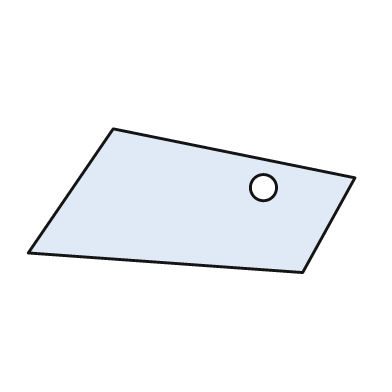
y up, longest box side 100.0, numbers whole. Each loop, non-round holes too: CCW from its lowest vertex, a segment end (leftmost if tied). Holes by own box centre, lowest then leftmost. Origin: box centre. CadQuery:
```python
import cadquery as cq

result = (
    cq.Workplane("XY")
    .moveTo(34.0, -22.0)
    .lineTo(50.0, 7.0)
    .lineTo(-24.0, 22.0)
    .lineTo(-50.0, -16.0)
    .close()
    .moveTo(22.0, 4.0)
    .circle(4.0)
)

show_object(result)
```